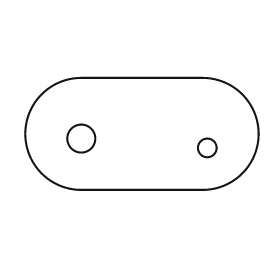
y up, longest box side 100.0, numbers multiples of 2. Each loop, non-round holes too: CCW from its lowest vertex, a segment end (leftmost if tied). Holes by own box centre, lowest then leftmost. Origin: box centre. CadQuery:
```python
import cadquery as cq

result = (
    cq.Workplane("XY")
    .moveTo(-26.0, -24.0)
    .lineTo(26.0, -24.0)
    .threePointArc((50.0, 0.0), (26.0, 24.0))
    .lineTo(-26.0, 24.0)
    .threePointArc((-50.0, 0.0), (-26.0, -24.0))
    .close()
    .moveTo(28.0, -6.0)
    .circle(4.0)
    .moveTo(-26.0, -2.0)
    .circle(6.0)
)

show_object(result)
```